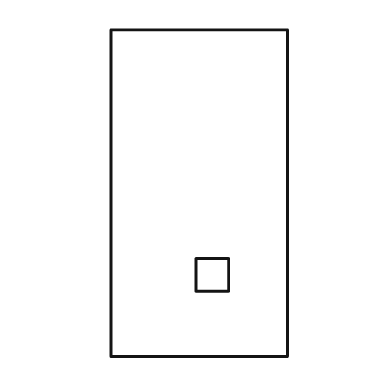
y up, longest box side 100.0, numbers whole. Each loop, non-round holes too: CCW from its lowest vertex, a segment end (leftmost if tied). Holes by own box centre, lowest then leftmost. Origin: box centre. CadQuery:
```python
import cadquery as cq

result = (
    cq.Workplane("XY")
    .moveTo(-27.0, -50.0)
    .lineTo(27.0, -50.0)
    .lineTo(27.0, 50.0)
    .lineTo(-27.0, 50.0)
    .close()
    .moveTo(-1.0, -30.0)
    .lineTo(9.0, -30.0)
    .lineTo(9.0, -20.0)
    .lineTo(-1.0, -20.0)
    .close()
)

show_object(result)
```